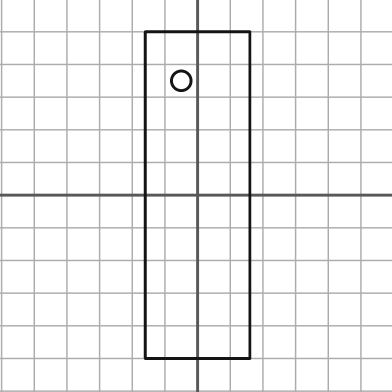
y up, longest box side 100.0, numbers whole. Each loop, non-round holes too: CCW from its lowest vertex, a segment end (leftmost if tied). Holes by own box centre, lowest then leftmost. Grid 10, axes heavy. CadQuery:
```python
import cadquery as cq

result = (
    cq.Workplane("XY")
    .moveTo(-16.0, -50.0)
    .lineTo(16.0, -50.0)
    .lineTo(16.0, 50.0)
    .lineTo(-16.0, 50.0)
    .close()
    .moveTo(-5.0, 35.0)
    .circle(3.0)
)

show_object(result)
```